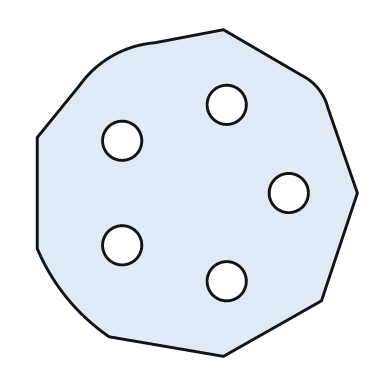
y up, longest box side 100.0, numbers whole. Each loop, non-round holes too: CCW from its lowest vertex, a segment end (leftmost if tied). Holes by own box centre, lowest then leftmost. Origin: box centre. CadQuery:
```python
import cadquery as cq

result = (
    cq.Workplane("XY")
    .moveTo(8.0, -50.0)
    .lineTo(38.0, -33.0)
    .lineTo(49.0, 0.0)
    .lineTo(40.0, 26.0)
    .threePointArc((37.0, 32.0), (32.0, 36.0))
    .lineTo(8.0, 50.0)
    .lineTo(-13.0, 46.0)
    .threePointArc((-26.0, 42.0), (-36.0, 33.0))
    .lineTo(-49.0, 17.0)
    .lineTo(-49.0, -17.0)
    .threePointArc((-40.0, -32.0), (-27.0, -44.0))
    .close()
    .moveTo(9.0, -27.0)
    .circle(6.0)
    .moveTo(-23.0, -16.0)
    .circle(6.0)
    .moveTo(28.0, 0.0)
    .circle(6.0)
    .moveTo(-23.0, 16.0)
    .circle(6.0)
    .moveTo(9.0, 27.0)
    .circle(6.0)
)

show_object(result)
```